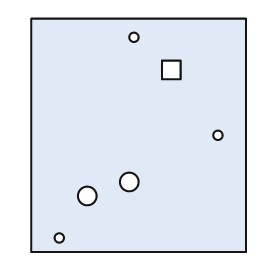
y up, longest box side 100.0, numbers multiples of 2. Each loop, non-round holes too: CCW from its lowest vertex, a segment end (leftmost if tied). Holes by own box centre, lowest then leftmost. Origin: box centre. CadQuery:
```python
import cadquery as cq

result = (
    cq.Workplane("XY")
    .moveTo(-46.0, -50.0)
    .lineTo(46.0, -50.0)
    .lineTo(46.0, 50.0)
    .lineTo(-46.0, 50.0)
    .close()
    .moveTo(-34.0, -44.0)
    .circle(2.0)
    .moveTo(-22.0, -26.0)
    .circle(4.0)
    .moveTo(-4.0, -20.0)
    .circle(4.0)
    .moveTo(34.0, 0.0)
    .circle(2.0)
    .moveTo(10.0, 24.0)
    .lineTo(18.0, 24.0)
    .lineTo(18.0, 32.0)
    .lineTo(10.0, 32.0)
    .close()
    .moveTo(-2.0, 42.0)
    .circle(2.0)
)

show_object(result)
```